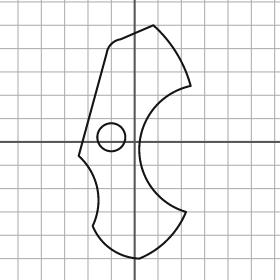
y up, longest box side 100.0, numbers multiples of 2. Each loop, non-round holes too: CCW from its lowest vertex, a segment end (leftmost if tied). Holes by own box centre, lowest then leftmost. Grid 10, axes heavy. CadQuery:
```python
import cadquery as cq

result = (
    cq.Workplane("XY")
    .moveTo(2.0, -50.0)
    .threePointArc((14.0, -42.0), (22.0, -30.0))
    .threePointArc((2.0, -2.0), (24.0, 24.0))
    .threePointArc((18.0, 38.0), (8.0, 50.0))
    .lineTo(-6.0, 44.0)
    .threePointArc((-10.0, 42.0), (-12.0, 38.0))
    .lineTo(-24.0, -6.0)
    .threePointArc((-16.0, -20.0), (-18.0, -36.0))
    .threePointArc((-10.0, -46.0), (2.0, -50.0))
    .close()
    .moveTo(-10.0, 2.0)
    .circle(6.0)
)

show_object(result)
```